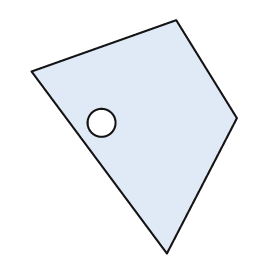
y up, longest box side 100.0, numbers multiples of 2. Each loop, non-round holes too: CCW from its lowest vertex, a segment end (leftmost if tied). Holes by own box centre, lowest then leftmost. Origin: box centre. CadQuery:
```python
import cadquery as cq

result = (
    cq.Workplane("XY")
    .moveTo(14.0, -50.0)
    .lineTo(44.0, 8.0)
    .lineTo(18.0, 50.0)
    .lineTo(-44.0, 28.0)
    .close()
    .moveTo(-14.0, 6.0)
    .circle(6.0)
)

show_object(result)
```